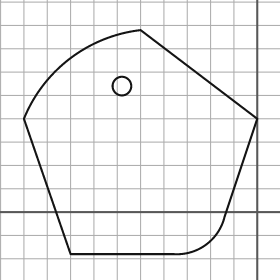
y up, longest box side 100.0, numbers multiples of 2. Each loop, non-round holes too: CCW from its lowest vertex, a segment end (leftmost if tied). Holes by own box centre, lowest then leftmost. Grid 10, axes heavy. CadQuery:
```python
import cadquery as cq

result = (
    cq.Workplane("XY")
    .moveTo(-80.0, -18.0)
    .lineTo(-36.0, -18.0)
    .threePointArc((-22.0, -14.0), (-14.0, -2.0))
    .lineTo(0.0, 40.0)
    .lineTo(-50.0, 78.0)
    .threePointArc((-80.0, 66.0), (-100.0, 40.0))
    .close()
    .moveTo(-58.0, 54.0)
    .circle(4.0)
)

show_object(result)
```